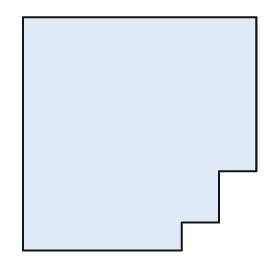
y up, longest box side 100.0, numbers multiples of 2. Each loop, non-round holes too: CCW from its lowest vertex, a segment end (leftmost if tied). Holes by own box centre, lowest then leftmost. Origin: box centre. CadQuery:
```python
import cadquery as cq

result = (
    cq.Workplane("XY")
    .moveTo(-50.0, -50.0)
    .lineTo(18.0, -50.0)
    .lineTo(18.0, -38.0)
    .lineTo(34.0, -38.0)
    .lineTo(34.0, -16.0)
    .lineTo(50.0, -16.0)
    .lineTo(50.0, 50.0)
    .lineTo(-50.0, 50.0)
    .close()
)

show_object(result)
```